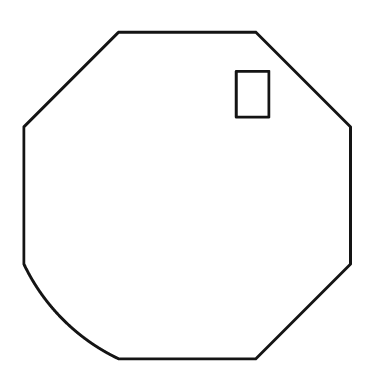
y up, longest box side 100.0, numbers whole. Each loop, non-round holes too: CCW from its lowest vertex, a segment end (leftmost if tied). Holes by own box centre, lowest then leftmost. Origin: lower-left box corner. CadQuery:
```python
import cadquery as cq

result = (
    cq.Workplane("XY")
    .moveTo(29.0, 0.0)
    .lineTo(71.0, 0.0)
    .lineTo(100.0, 29.0)
    .lineTo(100.0, 71.0)
    .lineTo(71.0, 100.0)
    .lineTo(29.0, 100.0)
    .lineTo(0.0, 71.0)
    .lineTo(0.0, 29.0)
    .threePointArc((12.0, 12.0), (29.0, 0.0))
    .close()
    .moveTo(65.0, 74.0)
    .lineTo(75.0, 74.0)
    .lineTo(75.0, 88.0)
    .lineTo(65.0, 88.0)
    .close()
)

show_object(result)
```